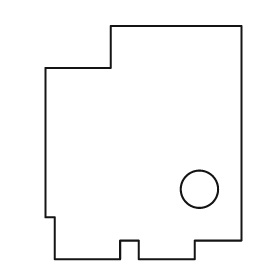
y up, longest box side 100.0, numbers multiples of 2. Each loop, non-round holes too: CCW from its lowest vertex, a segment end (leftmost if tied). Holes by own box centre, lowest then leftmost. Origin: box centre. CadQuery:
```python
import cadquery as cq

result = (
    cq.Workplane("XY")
    .moveTo(-38.0, -50.0)
    .lineTo(-10.0, -50.0)
    .lineTo(-10.0, -42.0)
    .lineTo(-2.0, -42.0)
    .lineTo(-2.0, -50.0)
    .lineTo(22.0, -50.0)
    .lineTo(22.0, -42.0)
    .lineTo(42.0, -42.0)
    .lineTo(42.0, 50.0)
    .lineTo(-14.0, 50.0)
    .lineTo(-14.0, 32.0)
    .lineTo(-42.0, 32.0)
    .lineTo(-42.0, -32.0)
    .lineTo(-38.0, -32.0)
    .close()
    .moveTo(24.0, -20.0)
    .circle(8.0)
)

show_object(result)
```